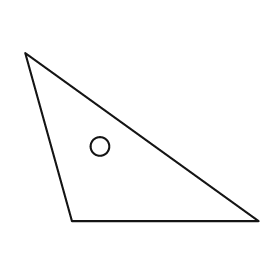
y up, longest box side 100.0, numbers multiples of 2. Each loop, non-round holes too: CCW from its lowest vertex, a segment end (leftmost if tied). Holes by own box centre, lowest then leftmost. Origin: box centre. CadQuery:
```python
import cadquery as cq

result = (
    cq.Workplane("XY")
    .moveTo(-30.0, -36.0)
    .lineTo(50.0, -36.0)
    .lineTo(-50.0, 36.0)
    .close()
    .moveTo(-18.0, -4.0)
    .circle(4.0)
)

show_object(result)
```